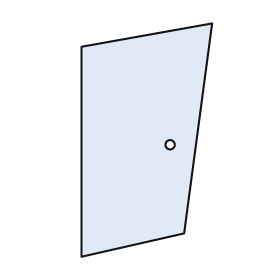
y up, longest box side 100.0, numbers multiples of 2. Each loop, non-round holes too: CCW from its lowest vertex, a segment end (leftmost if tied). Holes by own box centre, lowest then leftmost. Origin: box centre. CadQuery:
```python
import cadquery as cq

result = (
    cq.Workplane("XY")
    .moveTo(-28.0, -50.0)
    .lineTo(16.0, -40.0)
    .lineTo(28.0, 50.0)
    .lineTo(-28.0, 40.0)
    .close()
    .moveTo(10.0, -2.0)
    .circle(2.0)
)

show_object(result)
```